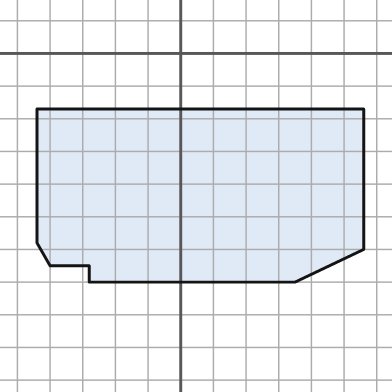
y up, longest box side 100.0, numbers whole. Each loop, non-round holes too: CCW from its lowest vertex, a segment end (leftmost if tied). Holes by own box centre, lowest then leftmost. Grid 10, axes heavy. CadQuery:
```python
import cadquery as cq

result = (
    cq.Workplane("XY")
    .moveTo(-28.0, -70.0)
    .lineTo(35.0, -70.0)
    .lineTo(56.0, -60.0)
    .lineTo(56.0, -17.0)
    .lineTo(-44.0, -17.0)
    .lineTo(-44.0, -58.0)
    .lineTo(-40.0, -65.0)
    .lineTo(-28.0, -65.0)
    .close()
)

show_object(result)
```